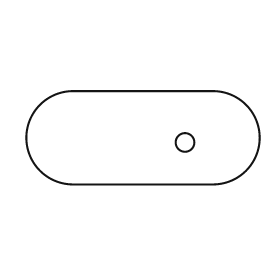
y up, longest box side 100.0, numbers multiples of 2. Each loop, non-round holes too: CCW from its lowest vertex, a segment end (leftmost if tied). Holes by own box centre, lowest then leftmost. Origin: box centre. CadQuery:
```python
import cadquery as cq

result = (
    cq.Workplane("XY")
    .moveTo(-30.0, -20.0)
    .lineTo(30.0, -20.0)
    .threePointArc((50.0, 0.0), (30.0, 20.0))
    .lineTo(-30.0, 20.0)
    .threePointArc((-50.0, 0.0), (-30.0, -20.0))
    .close()
    .moveTo(18.0, -2.0)
    .circle(4.0)
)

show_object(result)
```